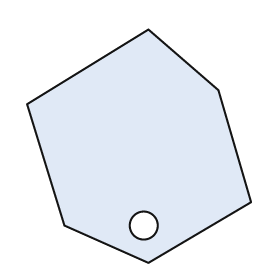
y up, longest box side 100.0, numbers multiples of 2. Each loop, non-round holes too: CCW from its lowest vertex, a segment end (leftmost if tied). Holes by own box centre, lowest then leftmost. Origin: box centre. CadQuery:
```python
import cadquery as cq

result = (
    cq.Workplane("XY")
    .moveTo(4.0, -50.0)
    .lineTo(48.0, -24.0)
    .lineTo(34.0, 24.0)
    .lineTo(4.0, 50.0)
    .lineTo(-48.0, 18.0)
    .lineTo(-32.0, -34.0)
    .close()
    .moveTo(2.0, -34.0)
    .circle(6.0)
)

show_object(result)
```